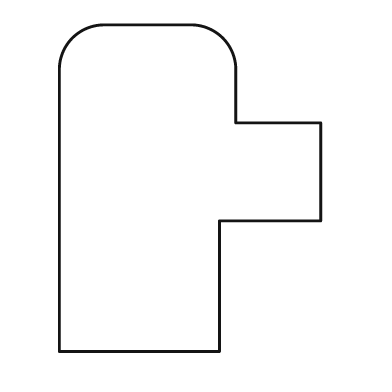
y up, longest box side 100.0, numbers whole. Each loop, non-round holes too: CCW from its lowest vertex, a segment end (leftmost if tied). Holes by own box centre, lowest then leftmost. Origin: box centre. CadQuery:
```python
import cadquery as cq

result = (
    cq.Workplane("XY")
    .moveTo(-40.0, -50.0)
    .lineTo(9.0, -50.0)
    .lineTo(9.0, -10.0)
    .lineTo(40.0, -10.0)
    .lineTo(40.0, 20.0)
    .lineTo(14.0, 20.0)
    .lineTo(14.0, 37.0)
    .threePointArc((10.0, 46.0), (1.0, 50.0))
    .lineTo(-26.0, 50.0)
    .threePointArc((-36.0, 46.0), (-40.0, 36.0))
    .close()
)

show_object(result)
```